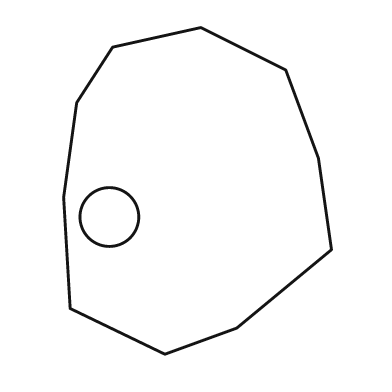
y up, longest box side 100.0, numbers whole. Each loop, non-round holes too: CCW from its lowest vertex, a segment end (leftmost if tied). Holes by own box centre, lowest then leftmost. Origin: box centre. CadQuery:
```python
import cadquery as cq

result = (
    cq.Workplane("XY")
    .moveTo(-10.0, -50.0)
    .lineTo(12.0, -42.0)
    .lineTo(41.0, -18.0)
    .lineTo(37.0, 10.0)
    .lineTo(27.0, 37.0)
    .lineTo(1.0, 50.0)
    .lineTo(-26.0, 44.0)
    .lineTo(-37.0, 27.0)
    .lineTo(-41.0, -2.0)
    .lineTo(-39.0, -36.0)
    .close()
    .moveTo(-27.0, -8.0)
    .circle(9.0)
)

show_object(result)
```